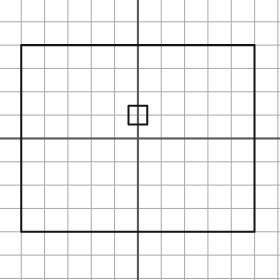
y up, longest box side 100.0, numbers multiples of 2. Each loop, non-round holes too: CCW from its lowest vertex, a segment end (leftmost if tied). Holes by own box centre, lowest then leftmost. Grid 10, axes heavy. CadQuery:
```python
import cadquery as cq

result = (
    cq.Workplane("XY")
    .moveTo(-50.0, -40.0)
    .lineTo(50.0, -40.0)
    .lineTo(50.0, 40.0)
    .lineTo(-50.0, 40.0)
    .close()
    .moveTo(-4.0, 6.0)
    .lineTo(4.0, 6.0)
    .lineTo(4.0, 14.0)
    .lineTo(-4.0, 14.0)
    .close()
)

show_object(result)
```